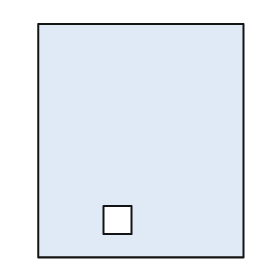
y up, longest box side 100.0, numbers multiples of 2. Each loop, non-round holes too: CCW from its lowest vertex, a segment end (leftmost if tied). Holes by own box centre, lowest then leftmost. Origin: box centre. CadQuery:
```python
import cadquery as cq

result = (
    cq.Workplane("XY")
    .moveTo(-44.0, -50.0)
    .lineTo(44.0, -50.0)
    .lineTo(44.0, 50.0)
    .lineTo(-44.0, 50.0)
    .close()
    .moveTo(-16.0, -40.0)
    .lineTo(-4.0, -40.0)
    .lineTo(-4.0, -28.0)
    .lineTo(-16.0, -28.0)
    .close()
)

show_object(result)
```